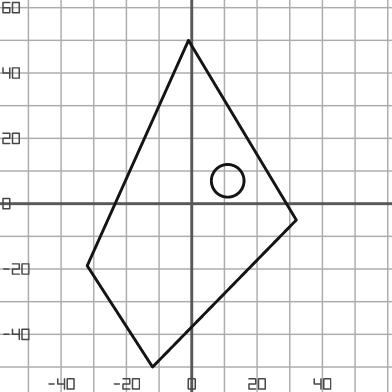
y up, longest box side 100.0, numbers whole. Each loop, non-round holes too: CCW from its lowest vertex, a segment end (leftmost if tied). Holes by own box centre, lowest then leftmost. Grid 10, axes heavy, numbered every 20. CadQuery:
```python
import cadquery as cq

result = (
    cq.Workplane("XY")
    .moveTo(-12.0, -50.0)
    .lineTo(32.0, -5.0)
    .lineTo(-1.0, 50.0)
    .lineTo(-32.0, -19.0)
    .close()
    .moveTo(11.0, 7.0)
    .circle(5.0)
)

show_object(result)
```